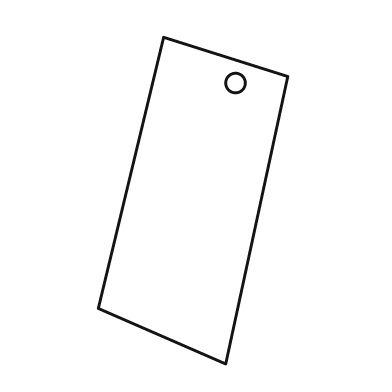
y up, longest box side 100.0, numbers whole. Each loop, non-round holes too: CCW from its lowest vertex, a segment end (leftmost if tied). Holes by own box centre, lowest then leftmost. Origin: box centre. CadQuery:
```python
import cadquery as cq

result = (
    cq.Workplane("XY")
    .moveTo(10.0, -50.0)
    .lineTo(29.0, 38.0)
    .lineTo(-9.0, 50.0)
    .lineTo(-29.0, -33.0)
    .close()
    .moveTo(13.0, 36.0)
    .circle(3.0)
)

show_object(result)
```